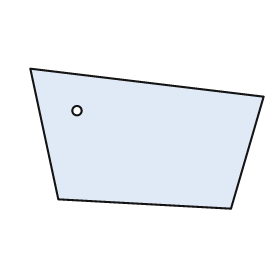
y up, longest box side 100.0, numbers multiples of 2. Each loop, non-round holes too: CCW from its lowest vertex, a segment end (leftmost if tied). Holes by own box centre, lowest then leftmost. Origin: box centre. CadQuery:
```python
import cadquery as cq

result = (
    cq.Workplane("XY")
    .moveTo(36.0, -30.0)
    .lineTo(50.0, 18.0)
    .lineTo(-50.0, 30.0)
    .lineTo(-38.0, -26.0)
    .close()
    .moveTo(-30.0, 12.0)
    .circle(2.0)
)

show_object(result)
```